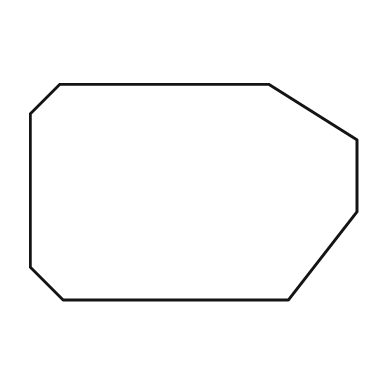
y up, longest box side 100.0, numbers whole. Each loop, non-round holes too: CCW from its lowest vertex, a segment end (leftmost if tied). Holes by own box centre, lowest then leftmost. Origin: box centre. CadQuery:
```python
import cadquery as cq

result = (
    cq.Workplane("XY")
    .moveTo(-40.0, -33.0)
    .lineTo(29.0, -33.0)
    .lineTo(50.0, -6.0)
    .lineTo(50.0, 16.0)
    .lineTo(23.0, 33.0)
    .lineTo(-41.0, 33.0)
    .lineTo(-50.0, 24.0)
    .lineTo(-50.0, -23.0)
    .close()
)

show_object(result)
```